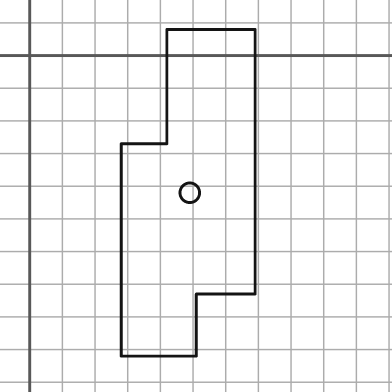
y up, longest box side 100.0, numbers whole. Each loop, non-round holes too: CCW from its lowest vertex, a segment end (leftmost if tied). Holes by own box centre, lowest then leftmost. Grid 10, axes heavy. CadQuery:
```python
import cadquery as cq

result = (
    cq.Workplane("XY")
    .moveTo(28.0, -92.0)
    .lineTo(51.0, -92.0)
    .lineTo(51.0, -73.0)
    .lineTo(69.0, -73.0)
    .lineTo(69.0, 8.0)
    .lineTo(42.0, 8.0)
    .lineTo(42.0, -27.0)
    .lineTo(28.0, -27.0)
    .close()
    .moveTo(49.0, -42.0)
    .circle(3.0)
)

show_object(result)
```